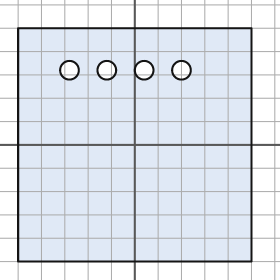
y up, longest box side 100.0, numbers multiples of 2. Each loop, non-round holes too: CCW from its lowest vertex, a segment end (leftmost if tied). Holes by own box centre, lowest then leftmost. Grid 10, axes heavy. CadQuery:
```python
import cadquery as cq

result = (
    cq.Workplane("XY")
    .moveTo(-50.0, -50.0)
    .lineTo(50.0, -50.0)
    .lineTo(50.0, 50.0)
    .lineTo(-50.0, 50.0)
    .close()
    .moveTo(-28.0, 32.0)
    .circle(4.0)
    .moveTo(-12.0, 32.0)
    .circle(4.0)
    .moveTo(4.0, 32.0)
    .circle(4.0)
    .moveTo(20.0, 32.0)
    .circle(4.0)
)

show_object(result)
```